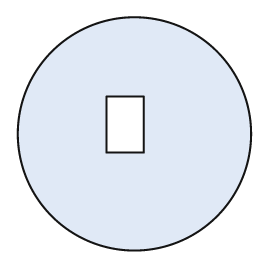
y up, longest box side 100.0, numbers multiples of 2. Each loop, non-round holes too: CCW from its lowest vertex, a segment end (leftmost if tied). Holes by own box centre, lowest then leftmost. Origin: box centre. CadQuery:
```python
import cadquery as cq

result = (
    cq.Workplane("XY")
    .moveTo(0.0, 0.0)
    .circle(50.0)
    .moveTo(-12.0, -8.0)
    .lineTo(4.0, -8.0)
    .lineTo(4.0, 16.0)
    .lineTo(-12.0, 16.0)
    .close()
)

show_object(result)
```